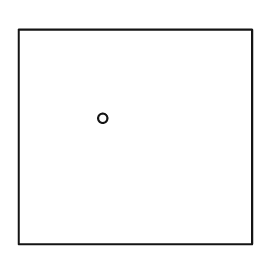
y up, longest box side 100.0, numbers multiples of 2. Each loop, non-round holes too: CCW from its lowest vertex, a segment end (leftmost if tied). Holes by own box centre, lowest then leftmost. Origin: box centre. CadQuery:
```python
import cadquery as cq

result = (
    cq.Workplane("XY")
    .moveTo(-50.0, -46.0)
    .lineTo(50.0, -46.0)
    .lineTo(50.0, 46.0)
    .lineTo(-50.0, 46.0)
    .close()
    .moveTo(-14.0, 8.0)
    .circle(2.0)
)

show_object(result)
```